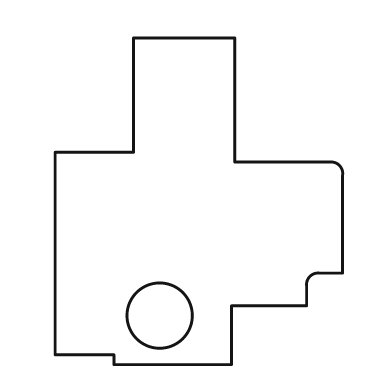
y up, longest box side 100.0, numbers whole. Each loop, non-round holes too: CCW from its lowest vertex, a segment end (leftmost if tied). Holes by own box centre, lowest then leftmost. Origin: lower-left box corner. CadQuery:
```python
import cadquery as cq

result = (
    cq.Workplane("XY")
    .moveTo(18.0, 0.0)
    .lineTo(54.0, 0.0)
    .lineTo(54.0, 18.0)
    .lineTo(77.0, 18.0)
    .lineTo(77.0, 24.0)
    .threePointArc((78.0, 27.0), (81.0, 28.0))
    .lineTo(88.0, 28.0)
    .lineTo(88.0, 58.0)
    .threePointArc((87.0, 61.0), (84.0, 62.0))
    .lineTo(55.0, 62.0)
    .lineTo(55.0, 100.0)
    .lineTo(24.0, 100.0)
    .lineTo(24.0, 65.0)
    .lineTo(0.0, 65.0)
    .lineTo(0.0, 3.0)
    .lineTo(18.0, 3.0)
    .close()
    .moveTo(32.0, 15.0)
    .circle(10.0)
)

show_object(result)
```